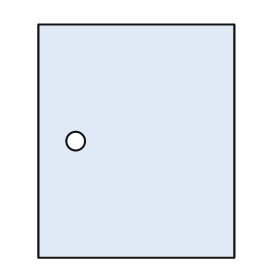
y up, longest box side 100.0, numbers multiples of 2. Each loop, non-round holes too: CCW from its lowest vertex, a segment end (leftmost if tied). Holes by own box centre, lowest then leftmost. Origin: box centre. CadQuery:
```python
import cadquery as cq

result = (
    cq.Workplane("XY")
    .moveTo(-42.0, -50.0)
    .lineTo(42.0, -50.0)
    .lineTo(42.0, 50.0)
    .lineTo(-42.0, 50.0)
    .close()
    .moveTo(-26.0, 0.0)
    .circle(4.0)
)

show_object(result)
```